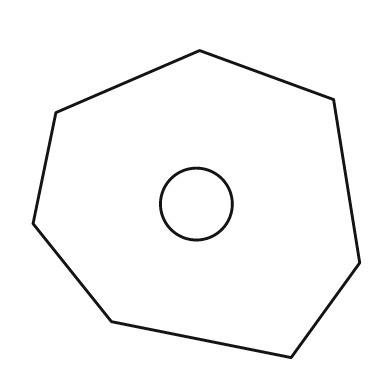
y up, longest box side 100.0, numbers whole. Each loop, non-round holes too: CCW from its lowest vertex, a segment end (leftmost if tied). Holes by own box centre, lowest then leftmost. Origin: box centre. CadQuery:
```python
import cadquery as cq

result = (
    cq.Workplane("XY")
    .moveTo(29.0, -47.0)
    .lineTo(50.0, -18.0)
    .lineTo(42.0, 32.0)
    .lineTo(1.0, 47.0)
    .lineTo(-43.0, 28.0)
    .lineTo(-50.0, -6.0)
    .lineTo(-26.0, -36.0)
    .close()
    .moveTo(0.0, 0.0)
    .circle(11.0)
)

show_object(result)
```